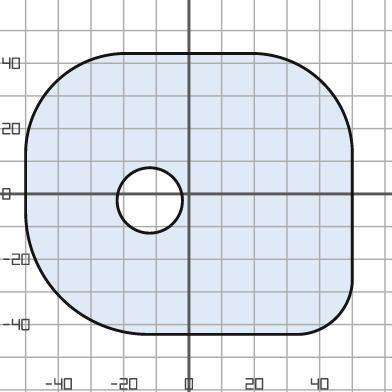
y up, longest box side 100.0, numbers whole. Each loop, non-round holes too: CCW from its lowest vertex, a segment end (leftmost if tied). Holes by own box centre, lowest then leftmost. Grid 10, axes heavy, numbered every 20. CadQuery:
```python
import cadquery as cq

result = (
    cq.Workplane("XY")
    .moveTo(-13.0, -43.0)
    .lineTo(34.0, -43.0)
    .threePointArc((45.0, -38.0), (50.0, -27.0))
    .lineTo(50.0, 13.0)
    .threePointArc((41.0, 34.0), (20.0, 43.0))
    .lineTo(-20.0, 43.0)
    .threePointArc((-41.0, 34.0), (-50.0, 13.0))
    .lineTo(-50.0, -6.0)
    .threePointArc((-39.0, -32.0), (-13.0, -43.0))
    .close()
    .moveTo(-12.0, -2.0)
    .circle(10.0)
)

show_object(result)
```